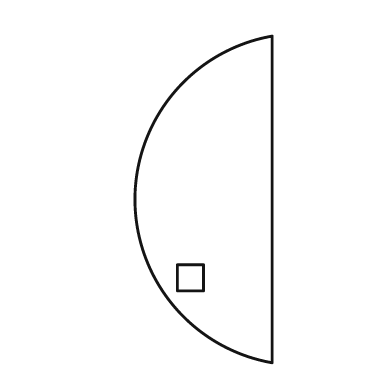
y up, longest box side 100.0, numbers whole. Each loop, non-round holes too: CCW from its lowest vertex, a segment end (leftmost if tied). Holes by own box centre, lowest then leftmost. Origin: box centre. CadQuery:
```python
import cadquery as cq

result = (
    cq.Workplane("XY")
    .moveTo(21.0, -50.0)
    .lineTo(21.0, 50.0)
    .threePointArc((-21.0, 0.0), (21.0, -50.0))
    .close()
    .moveTo(-8.0, -28.0)
    .lineTo(0.0, -28.0)
    .lineTo(0.0, -20.0)
    .lineTo(-8.0, -20.0)
    .close()
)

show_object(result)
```